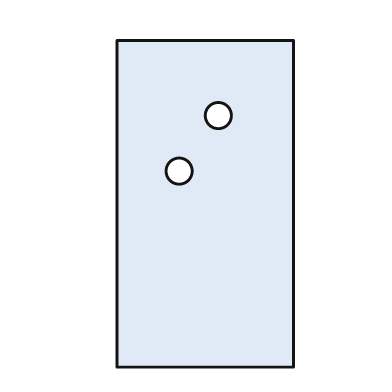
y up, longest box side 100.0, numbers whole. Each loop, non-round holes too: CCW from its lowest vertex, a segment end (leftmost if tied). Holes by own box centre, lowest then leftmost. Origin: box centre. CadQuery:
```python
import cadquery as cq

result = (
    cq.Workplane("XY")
    .moveTo(-27.0, -50.0)
    .lineTo(27.0, -50.0)
    .lineTo(27.0, 50.0)
    .lineTo(-27.0, 50.0)
    .close()
    .moveTo(-8.0, 10.0)
    .circle(4.0)
    .moveTo(4.0, 27.0)
    .circle(4.0)
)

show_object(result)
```